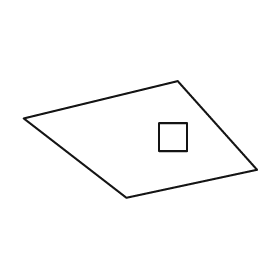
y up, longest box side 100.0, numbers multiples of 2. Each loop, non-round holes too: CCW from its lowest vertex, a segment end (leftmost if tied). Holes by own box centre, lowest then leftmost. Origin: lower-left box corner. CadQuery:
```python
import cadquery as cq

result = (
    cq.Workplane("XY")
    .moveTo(44.0, 0.0)
    .lineTo(100.0, 12.0)
    .lineTo(66.0, 50.0)
    .lineTo(0.0, 34.0)
    .close()
    .moveTo(58.0, 20.0)
    .lineTo(70.0, 20.0)
    .lineTo(70.0, 32.0)
    .lineTo(58.0, 32.0)
    .close()
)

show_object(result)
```